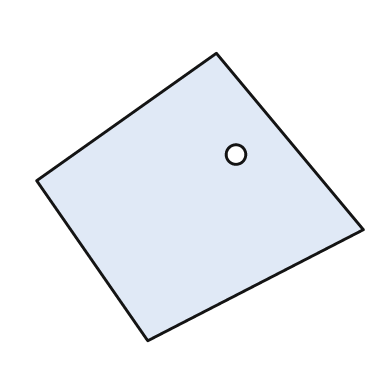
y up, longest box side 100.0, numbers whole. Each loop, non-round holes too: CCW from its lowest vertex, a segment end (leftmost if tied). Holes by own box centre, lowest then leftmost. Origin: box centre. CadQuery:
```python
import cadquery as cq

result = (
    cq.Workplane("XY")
    .moveTo(-16.0, -44.0)
    .lineTo(50.0, -10.0)
    .lineTo(5.0, 44.0)
    .lineTo(-50.0, 5.0)
    .close()
    .moveTo(11.0, 13.0)
    .circle(3.0)
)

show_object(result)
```